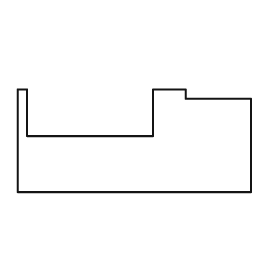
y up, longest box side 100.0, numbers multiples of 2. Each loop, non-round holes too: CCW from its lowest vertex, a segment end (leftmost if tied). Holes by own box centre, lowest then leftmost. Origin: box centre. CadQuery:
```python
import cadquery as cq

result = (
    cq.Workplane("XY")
    .moveTo(-50.0, -22.0)
    .lineTo(50.0, -22.0)
    .lineTo(50.0, 18.0)
    .lineTo(22.0, 18.0)
    .lineTo(22.0, 22.0)
    .lineTo(8.0, 22.0)
    .lineTo(8.0, 2.0)
    .lineTo(-46.0, 2.0)
    .lineTo(-46.0, 22.0)
    .lineTo(-50.0, 22.0)
    .close()
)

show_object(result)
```